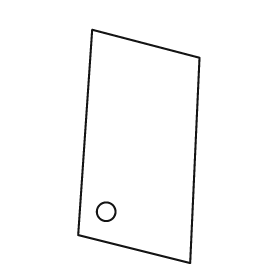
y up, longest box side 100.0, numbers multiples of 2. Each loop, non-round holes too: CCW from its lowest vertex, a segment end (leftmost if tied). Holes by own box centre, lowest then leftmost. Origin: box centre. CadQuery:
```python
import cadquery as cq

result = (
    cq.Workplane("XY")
    .moveTo(22.0, -50.0)
    .lineTo(26.0, 38.0)
    .lineTo(-20.0, 50.0)
    .lineTo(-26.0, -38.0)
    .close()
    .moveTo(-14.0, -28.0)
    .circle(4.0)
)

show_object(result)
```